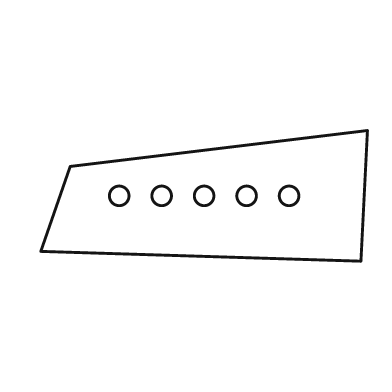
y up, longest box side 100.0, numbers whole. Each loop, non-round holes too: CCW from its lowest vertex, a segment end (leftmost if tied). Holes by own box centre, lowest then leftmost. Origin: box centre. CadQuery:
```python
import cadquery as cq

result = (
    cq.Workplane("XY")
    .moveTo(48.0, -20.0)
    .lineTo(50.0, 20.0)
    .lineTo(-41.0, 9.0)
    .lineTo(-50.0, -17.0)
    .close()
    .moveTo(-26.0, 0.0)
    .circle(3.0)
    .moveTo(-13.0, 0.0)
    .circle(3.0)
    .moveTo(0.0, 0.0)
    .circle(3.0)
    .moveTo(13.0, 0.0)
    .circle(3.0)
    .moveTo(26.0, 0.0)
    .circle(3.0)
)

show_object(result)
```